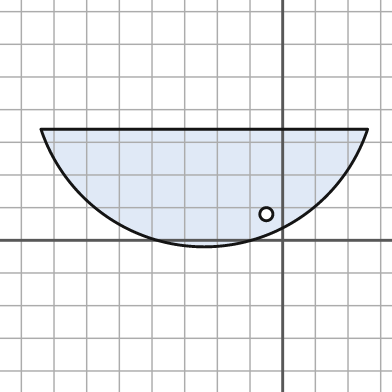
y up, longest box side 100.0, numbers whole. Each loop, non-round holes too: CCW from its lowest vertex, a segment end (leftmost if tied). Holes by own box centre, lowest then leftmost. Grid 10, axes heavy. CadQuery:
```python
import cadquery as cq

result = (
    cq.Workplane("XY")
    .moveTo(-74.0, 34.0)
    .threePointArc((-24.0, -2.0), (26.0, 34.0))
    .close()
    .moveTo(-5.0, 8.0)
    .circle(2.0)
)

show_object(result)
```